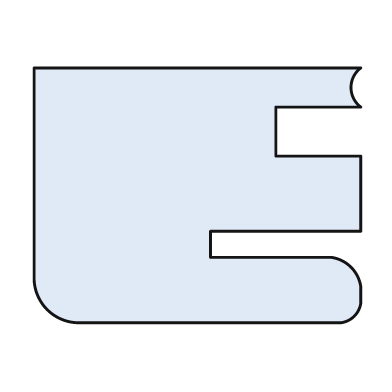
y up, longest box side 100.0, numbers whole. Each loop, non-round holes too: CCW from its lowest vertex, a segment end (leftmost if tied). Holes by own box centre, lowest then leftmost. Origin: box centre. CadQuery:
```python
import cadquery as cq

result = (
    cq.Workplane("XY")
    .moveTo(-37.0, -39.0)
    .lineTo(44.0, -39.0)
    .threePointArc((48.0, -37.0), (50.0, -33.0))
    .lineTo(50.0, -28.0)
    .threePointArc((47.0, -22.0), (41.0, -19.0))
    .lineTo(4.0, -19.0)
    .lineTo(4.0, -11.0)
    .lineTo(50.0, -11.0)
    .lineTo(50.0, 12.0)
    .lineTo(24.0, 12.0)
    .lineTo(24.0, 27.0)
    .lineTo(50.0, 27.0)
    .threePointArc((47.0, 33.0), (50.0, 39.0))
    .lineTo(-50.0, 39.0)
    .lineTo(-50.0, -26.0)
    .threePointArc((-46.0, -35.0), (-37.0, -39.0))
    .close()
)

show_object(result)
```